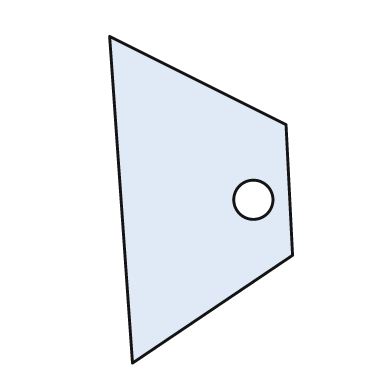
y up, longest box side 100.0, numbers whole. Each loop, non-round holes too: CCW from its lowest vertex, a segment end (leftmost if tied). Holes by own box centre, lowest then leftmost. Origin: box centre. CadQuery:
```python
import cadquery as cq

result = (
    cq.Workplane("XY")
    .moveTo(-21.0, -50.0)
    .lineTo(28.0, -17.0)
    .lineTo(26.0, 23.0)
    .lineTo(-28.0, 50.0)
    .close()
    .moveTo(16.0, 0.0)
    .circle(6.0)
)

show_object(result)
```